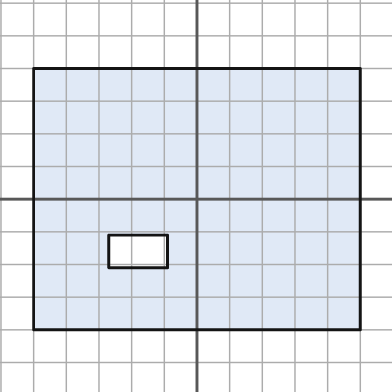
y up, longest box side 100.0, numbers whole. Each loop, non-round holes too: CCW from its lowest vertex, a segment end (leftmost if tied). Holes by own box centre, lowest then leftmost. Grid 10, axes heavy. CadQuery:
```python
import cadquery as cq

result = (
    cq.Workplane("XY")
    .moveTo(-50.0, -40.0)
    .lineTo(50.0, -40.0)
    .lineTo(50.0, 40.0)
    .lineTo(-50.0, 40.0)
    .close()
    .moveTo(-27.0, -21.0)
    .lineTo(-9.0, -21.0)
    .lineTo(-9.0, -11.0)
    .lineTo(-27.0, -11.0)
    .close()
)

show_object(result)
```